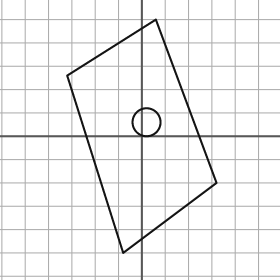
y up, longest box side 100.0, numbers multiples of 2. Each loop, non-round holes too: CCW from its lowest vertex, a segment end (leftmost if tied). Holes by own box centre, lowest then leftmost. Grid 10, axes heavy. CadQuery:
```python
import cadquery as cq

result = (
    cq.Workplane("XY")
    .moveTo(-8.0, -50.0)
    .lineTo(32.0, -20.0)
    .lineTo(6.0, 50.0)
    .lineTo(-32.0, 26.0)
    .close()
    .moveTo(2.0, 6.0)
    .circle(6.0)
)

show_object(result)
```